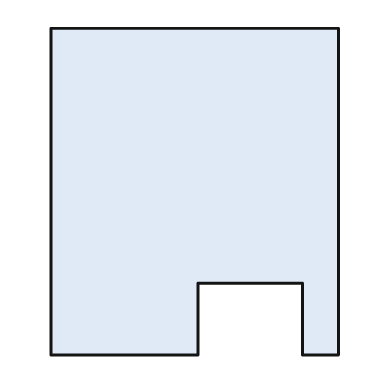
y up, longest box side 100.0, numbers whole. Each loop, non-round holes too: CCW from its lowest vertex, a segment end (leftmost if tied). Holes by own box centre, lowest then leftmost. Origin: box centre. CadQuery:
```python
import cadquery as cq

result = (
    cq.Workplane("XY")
    .moveTo(-44.0, -50.0)
    .lineTo(1.0, -50.0)
    .lineTo(1.0, -28.0)
    .lineTo(33.0, -28.0)
    .lineTo(33.0, -50.0)
    .lineTo(44.0, -50.0)
    .lineTo(44.0, 50.0)
    .lineTo(-44.0, 50.0)
    .close()
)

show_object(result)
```